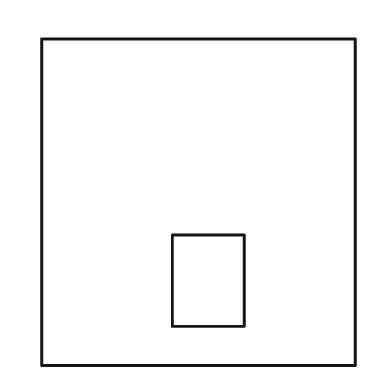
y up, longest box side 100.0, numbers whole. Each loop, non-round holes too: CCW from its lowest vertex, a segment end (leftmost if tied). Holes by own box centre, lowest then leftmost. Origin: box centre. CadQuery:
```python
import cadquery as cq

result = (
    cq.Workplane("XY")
    .moveTo(-48.0, -50.0)
    .lineTo(48.0, -50.0)
    .lineTo(48.0, 50.0)
    .lineTo(-48.0, 50.0)
    .close()
    .moveTo(-8.0, -38.0)
    .lineTo(14.0, -38.0)
    .lineTo(14.0, -10.0)
    .lineTo(-8.0, -10.0)
    .close()
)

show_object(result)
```